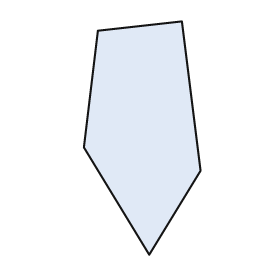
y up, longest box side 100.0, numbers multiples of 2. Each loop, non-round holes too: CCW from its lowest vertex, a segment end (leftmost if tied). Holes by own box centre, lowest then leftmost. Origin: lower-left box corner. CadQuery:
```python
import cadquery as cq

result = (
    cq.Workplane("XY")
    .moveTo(28.0, 0.0)
    .lineTo(50.0, 36.0)
    .lineTo(42.0, 100.0)
    .lineTo(6.0, 96.0)
    .lineTo(0.0, 46.0)
    .close()
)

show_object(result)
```